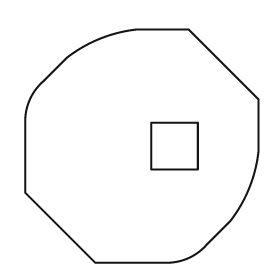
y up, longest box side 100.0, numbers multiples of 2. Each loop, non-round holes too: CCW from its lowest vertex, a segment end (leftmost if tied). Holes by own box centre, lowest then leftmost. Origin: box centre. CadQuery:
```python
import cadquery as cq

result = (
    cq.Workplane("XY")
    .moveTo(-20.0, -50.0)
    .lineTo(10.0, -50.0)
    .threePointArc((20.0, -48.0), (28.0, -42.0))
    .lineTo(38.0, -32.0)
    .threePointArc((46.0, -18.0), (50.0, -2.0))
    .lineTo(50.0, 20.0)
    .lineTo(20.0, 50.0)
    .lineTo(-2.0, 50.0)
    .threePointArc((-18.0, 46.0), (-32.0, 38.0))
    .lineTo(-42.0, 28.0)
    .threePointArc((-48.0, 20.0), (-50.0, 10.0))
    .lineTo(-50.0, -20.0)
    .close()
    .moveTo(4.0, -10.0)
    .lineTo(24.0, -10.0)
    .lineTo(24.0, 10.0)
    .lineTo(4.0, 10.0)
    .close()
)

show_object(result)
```